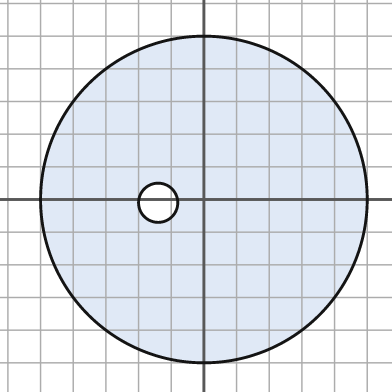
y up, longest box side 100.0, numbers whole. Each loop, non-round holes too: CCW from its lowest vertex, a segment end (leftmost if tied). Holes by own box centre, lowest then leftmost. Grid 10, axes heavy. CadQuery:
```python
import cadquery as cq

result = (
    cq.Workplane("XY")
    .moveTo(0.0, 0.0)
    .circle(50.0)
    .moveTo(-14.0, -1.0)
    .circle(6.0)
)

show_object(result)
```